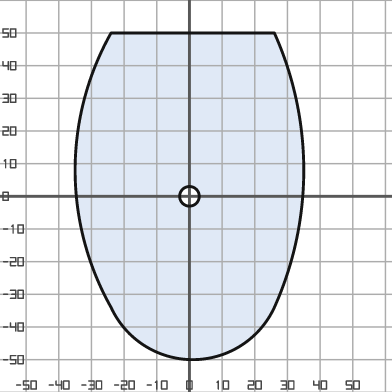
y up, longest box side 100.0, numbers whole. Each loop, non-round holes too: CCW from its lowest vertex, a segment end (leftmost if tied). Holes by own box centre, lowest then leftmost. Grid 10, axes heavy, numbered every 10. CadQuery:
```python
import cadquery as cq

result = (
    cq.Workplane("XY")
    .moveTo(-24.0, -34.0)
    .threePointArc((1.0, -50.0), (26.0, -34.0))
    .threePointArc((35.0, 8.0), (26.0, 50.0))
    .lineTo(-24.0, 50.0)
    .threePointArc((-35.0, 8.0), (-24.0, -34.0))
    .close()
    .moveTo(0.0, 0.0)
    .circle(3.0)
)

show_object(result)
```